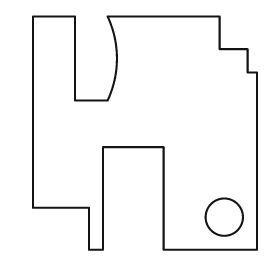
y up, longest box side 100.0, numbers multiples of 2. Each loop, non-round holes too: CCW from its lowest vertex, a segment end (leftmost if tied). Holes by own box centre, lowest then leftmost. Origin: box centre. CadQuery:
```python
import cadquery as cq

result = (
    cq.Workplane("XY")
    .moveTo(-24.0, -50.0)
    .lineTo(-18.0, -50.0)
    .lineTo(-18.0, -6.0)
    .lineTo(8.0, -6.0)
    .lineTo(8.0, -50.0)
    .lineTo(48.0, -50.0)
    .lineTo(48.0, 26.0)
    .lineTo(44.0, 26.0)
    .lineTo(44.0, 36.0)
    .lineTo(32.0, 36.0)
    .lineTo(32.0, 50.0)
    .lineTo(-16.0, 50.0)
    .threePointArc((-12.0, 32.0), (-16.0, 14.0))
    .lineTo(-30.0, 14.0)
    .lineTo(-30.0, 50.0)
    .lineTo(-48.0, 50.0)
    .lineTo(-48.0, -32.0)
    .lineTo(-24.0, -32.0)
    .close()
    .moveTo(34.0, -36.0)
    .circle(8.0)
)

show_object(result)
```